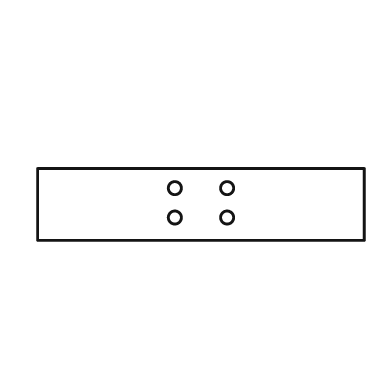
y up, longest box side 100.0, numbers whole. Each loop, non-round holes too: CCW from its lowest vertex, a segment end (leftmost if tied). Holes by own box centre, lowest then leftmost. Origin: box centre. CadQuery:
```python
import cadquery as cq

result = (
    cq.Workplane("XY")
    .moveTo(-50.0, -11.0)
    .lineTo(50.0, -11.0)
    .lineTo(50.0, 11.0)
    .lineTo(-50.0, 11.0)
    .close()
    .moveTo(-8.0, -4.0)
    .circle(2.0)
    .moveTo(8.0, -4.0)
    .circle(2.0)
    .moveTo(-8.0, 5.0)
    .circle(2.0)
    .moveTo(8.0, 5.0)
    .circle(2.0)
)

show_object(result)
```